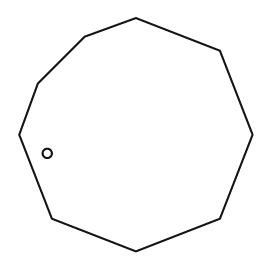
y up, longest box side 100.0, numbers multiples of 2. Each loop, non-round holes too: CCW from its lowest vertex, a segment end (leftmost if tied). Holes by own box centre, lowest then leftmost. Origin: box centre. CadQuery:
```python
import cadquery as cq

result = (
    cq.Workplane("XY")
    .moveTo(0.0, -50.0)
    .lineTo(36.0, -36.0)
    .lineTo(50.0, 0.0)
    .lineTo(36.0, 36.0)
    .lineTo(0.0, 50.0)
    .lineTo(-22.0, 42.0)
    .lineTo(-42.0, 22.0)
    .lineTo(-50.0, 0.0)
    .lineTo(-36.0, -36.0)
    .close()
    .moveTo(-38.0, -8.0)
    .circle(2.0)
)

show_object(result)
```